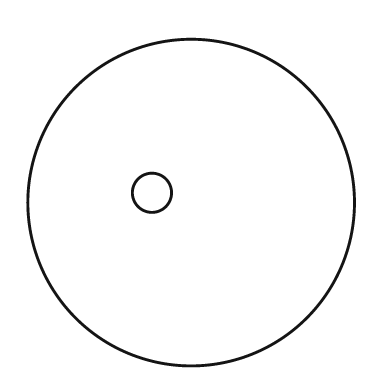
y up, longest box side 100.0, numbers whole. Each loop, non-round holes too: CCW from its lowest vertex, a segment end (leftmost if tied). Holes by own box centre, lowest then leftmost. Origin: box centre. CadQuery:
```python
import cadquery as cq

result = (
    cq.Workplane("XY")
    .moveTo(0.0, 0.0)
    .circle(50.0)
    .moveTo(-12.0, 3.0)
    .circle(6.0)
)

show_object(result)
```